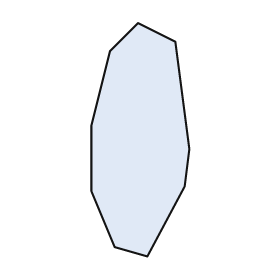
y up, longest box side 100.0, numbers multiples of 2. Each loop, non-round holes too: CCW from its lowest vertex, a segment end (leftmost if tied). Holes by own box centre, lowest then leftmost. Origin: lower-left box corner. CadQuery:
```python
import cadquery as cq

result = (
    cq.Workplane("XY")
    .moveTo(24.0, 0.0)
    .lineTo(40.0, 30.0)
    .lineTo(42.0, 46.0)
    .lineTo(36.0, 92.0)
    .lineTo(20.0, 100.0)
    .lineTo(8.0, 88.0)
    .lineTo(0.0, 56.0)
    .lineTo(0.0, 28.0)
    .lineTo(10.0, 4.0)
    .close()
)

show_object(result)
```